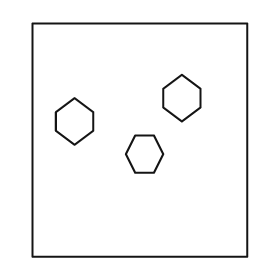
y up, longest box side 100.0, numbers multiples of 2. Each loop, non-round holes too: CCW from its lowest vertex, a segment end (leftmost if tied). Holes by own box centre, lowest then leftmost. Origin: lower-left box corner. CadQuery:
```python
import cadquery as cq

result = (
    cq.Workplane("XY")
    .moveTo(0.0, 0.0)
    .lineTo(92.0, 0.0)
    .lineTo(92.0, 100.0)
    .lineTo(0.0, 100.0)
    .close()
    .moveTo(44.0, 36.0)
    .lineTo(52.0, 36.0)
    .lineTo(56.0, 44.0)
    .lineTo(52.0, 52.0)
    .lineTo(44.0, 52.0)
    .lineTo(40.0, 44.0)
    .close()
    .moveTo(18.0, 48.0)
    .lineTo(26.0, 54.0)
    .lineTo(26.0, 62.0)
    .lineTo(18.0, 68.0)
    .lineTo(10.0, 62.0)
    .lineTo(10.0, 54.0)
    .close()
    .moveTo(64.0, 58.0)
    .lineTo(72.0, 64.0)
    .lineTo(72.0, 72.0)
    .lineTo(64.0, 78.0)
    .lineTo(56.0, 72.0)
    .lineTo(56.0, 64.0)
    .close()
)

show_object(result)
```